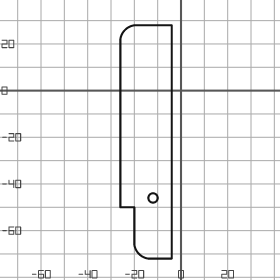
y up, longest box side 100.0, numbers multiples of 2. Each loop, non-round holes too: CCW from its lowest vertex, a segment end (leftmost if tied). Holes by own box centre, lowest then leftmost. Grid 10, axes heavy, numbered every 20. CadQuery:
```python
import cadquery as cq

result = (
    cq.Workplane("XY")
    .moveTo(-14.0, -72.0)
    .lineTo(-4.0, -72.0)
    .lineTo(-4.0, 28.0)
    .lineTo(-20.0, 28.0)
    .threePointArc((-24.0, 26.0), (-26.0, 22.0))
    .lineTo(-26.0, -50.0)
    .lineTo(-20.0, -50.0)
    .lineTo(-20.0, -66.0)
    .threePointArc((-18.0, -70.0), (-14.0, -72.0))
    .close()
    .moveTo(-12.0, -46.0)
    .circle(2.0)
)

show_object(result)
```